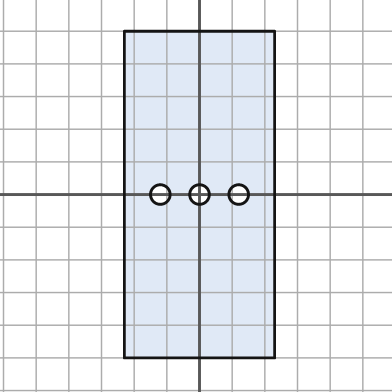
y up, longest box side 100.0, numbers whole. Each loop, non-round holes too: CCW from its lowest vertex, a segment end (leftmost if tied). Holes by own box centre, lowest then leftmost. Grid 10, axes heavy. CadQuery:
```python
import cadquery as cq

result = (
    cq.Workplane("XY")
    .moveTo(-23.0, -50.0)
    .lineTo(23.0, -50.0)
    .lineTo(23.0, 50.0)
    .lineTo(-23.0, 50.0)
    .close()
    .moveTo(-12.0, 0.0)
    .circle(3.0)
    .moveTo(0.0, 0.0)
    .circle(3.0)
    .moveTo(12.0, 0.0)
    .circle(3.0)
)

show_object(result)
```